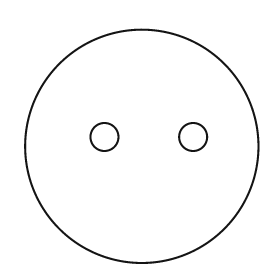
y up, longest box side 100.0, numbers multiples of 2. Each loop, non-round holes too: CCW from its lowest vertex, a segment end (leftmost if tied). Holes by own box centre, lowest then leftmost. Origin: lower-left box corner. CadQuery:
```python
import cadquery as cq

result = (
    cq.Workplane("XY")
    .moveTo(50.0, 50.0)
    .circle(50.0)
    .moveTo(34.0, 54.0)
    .circle(6.0)
    .moveTo(72.0, 54.0)
    .circle(6.0)
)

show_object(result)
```